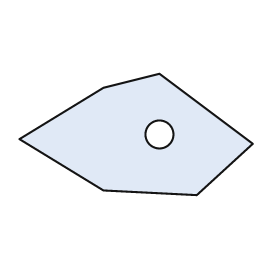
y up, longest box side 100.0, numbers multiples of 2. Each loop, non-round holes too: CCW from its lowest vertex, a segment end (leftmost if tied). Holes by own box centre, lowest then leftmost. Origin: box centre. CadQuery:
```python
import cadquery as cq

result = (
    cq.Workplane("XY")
    .moveTo(26.0, -26.0)
    .lineTo(50.0, -4.0)
    .lineTo(10.0, 26.0)
    .lineTo(-14.0, 20.0)
    .lineTo(-50.0, -2.0)
    .lineTo(-14.0, -24.0)
    .close()
    .moveTo(10.0, 0.0)
    .circle(6.0)
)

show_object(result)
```